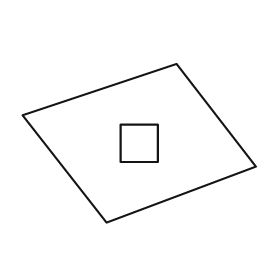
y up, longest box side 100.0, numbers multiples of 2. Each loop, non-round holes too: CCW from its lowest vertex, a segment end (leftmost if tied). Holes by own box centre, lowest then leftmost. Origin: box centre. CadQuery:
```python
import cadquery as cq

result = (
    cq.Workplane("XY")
    .moveTo(-14.0, -34.0)
    .lineTo(50.0, -10.0)
    .lineTo(16.0, 34.0)
    .lineTo(-50.0, 12.0)
    .close()
    .moveTo(-8.0, -8.0)
    .lineTo(8.0, -8.0)
    .lineTo(8.0, 8.0)
    .lineTo(-8.0, 8.0)
    .close()
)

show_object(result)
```